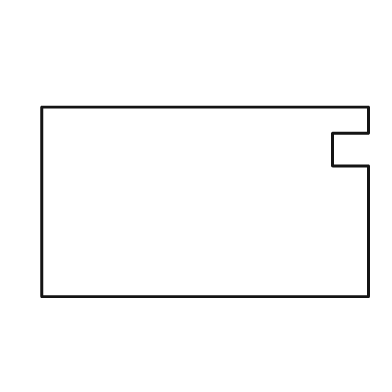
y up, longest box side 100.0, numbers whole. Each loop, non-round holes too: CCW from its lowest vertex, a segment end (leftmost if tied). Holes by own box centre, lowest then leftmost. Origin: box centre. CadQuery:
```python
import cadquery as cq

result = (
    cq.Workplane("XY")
    .moveTo(-50.0, -29.0)
    .lineTo(50.0, -29.0)
    .lineTo(50.0, 11.0)
    .lineTo(39.0, 11.0)
    .lineTo(39.0, 21.0)
    .lineTo(50.0, 21.0)
    .lineTo(50.0, 29.0)
    .lineTo(-50.0, 29.0)
    .close()
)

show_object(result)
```